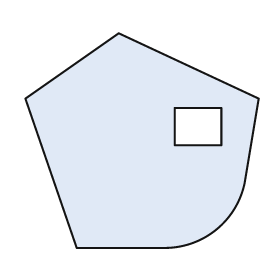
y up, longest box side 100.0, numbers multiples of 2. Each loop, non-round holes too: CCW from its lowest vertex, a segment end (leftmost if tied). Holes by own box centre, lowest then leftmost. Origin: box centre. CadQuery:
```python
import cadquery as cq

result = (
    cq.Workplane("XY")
    .moveTo(-28.0, -46.0)
    .lineTo(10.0, -46.0)
    .threePointArc((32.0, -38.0), (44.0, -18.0))
    .lineTo(50.0, 18.0)
    .lineTo(-10.0, 46.0)
    .lineTo(-50.0, 18.0)
    .close()
    .moveTo(14.0, -2.0)
    .lineTo(34.0, -2.0)
    .lineTo(34.0, 14.0)
    .lineTo(14.0, 14.0)
    .close()
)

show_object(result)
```